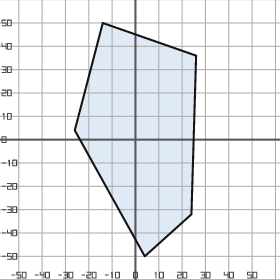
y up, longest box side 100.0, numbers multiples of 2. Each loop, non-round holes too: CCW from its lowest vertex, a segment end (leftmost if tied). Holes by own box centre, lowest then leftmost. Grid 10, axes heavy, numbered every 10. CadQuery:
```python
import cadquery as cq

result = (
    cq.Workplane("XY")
    .moveTo(4.0, -50.0)
    .lineTo(24.0, -32.0)
    .lineTo(26.0, 36.0)
    .lineTo(-14.0, 50.0)
    .lineTo(-26.0, 4.0)
    .close()
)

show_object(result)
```